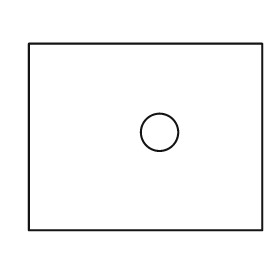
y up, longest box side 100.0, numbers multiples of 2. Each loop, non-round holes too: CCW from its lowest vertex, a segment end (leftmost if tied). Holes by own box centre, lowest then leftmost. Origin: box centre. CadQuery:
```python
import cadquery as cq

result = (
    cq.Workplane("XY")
    .moveTo(-50.0, -40.0)
    .lineTo(50.0, -40.0)
    .lineTo(50.0, 40.0)
    .lineTo(-50.0, 40.0)
    .close()
    .moveTo(6.0, 2.0)
    .circle(8.0)
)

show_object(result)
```